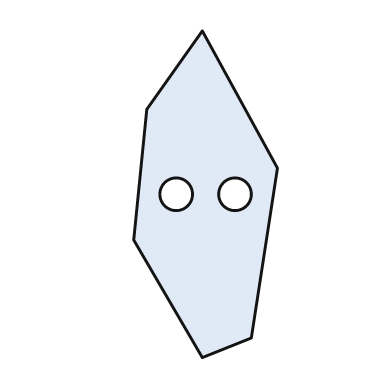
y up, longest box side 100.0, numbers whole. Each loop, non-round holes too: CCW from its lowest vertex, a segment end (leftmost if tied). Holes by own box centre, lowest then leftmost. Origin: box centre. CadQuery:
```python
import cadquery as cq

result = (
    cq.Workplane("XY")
    .moveTo(-1.0, -50.0)
    .lineTo(14.0, -44.0)
    .lineTo(22.0, 8.0)
    .lineTo(-1.0, 50.0)
    .lineTo(-18.0, 26.0)
    .lineTo(-22.0, -14.0)
    .close()
    .moveTo(-9.0, 0.0)
    .circle(5.0)
    .moveTo(9.0, 0.0)
    .circle(5.0)
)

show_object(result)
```